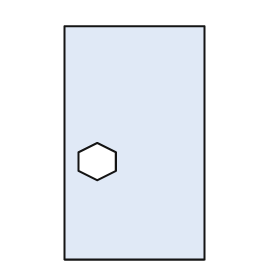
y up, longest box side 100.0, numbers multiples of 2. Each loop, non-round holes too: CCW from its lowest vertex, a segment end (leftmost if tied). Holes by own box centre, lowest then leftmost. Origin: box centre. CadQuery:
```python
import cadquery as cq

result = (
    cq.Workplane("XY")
    .moveTo(-30.0, -50.0)
    .lineTo(30.0, -50.0)
    .lineTo(30.0, 50.0)
    .lineTo(-30.0, 50.0)
    .close()
    .moveTo(-16.0, -16.0)
    .lineTo(-8.0, -12.0)
    .lineTo(-8.0, -4.0)
    .lineTo(-16.0, 0.0)
    .lineTo(-24.0, -4.0)
    .lineTo(-24.0, -12.0)
    .close()
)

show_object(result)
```